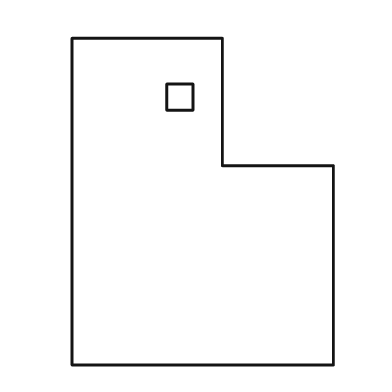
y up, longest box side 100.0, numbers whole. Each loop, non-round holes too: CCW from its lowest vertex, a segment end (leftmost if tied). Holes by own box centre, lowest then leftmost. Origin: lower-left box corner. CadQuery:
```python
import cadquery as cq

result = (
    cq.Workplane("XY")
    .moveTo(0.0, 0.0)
    .lineTo(80.0, 0.0)
    .lineTo(80.0, 61.0)
    .lineTo(46.0, 61.0)
    .lineTo(46.0, 100.0)
    .lineTo(0.0, 100.0)
    .close()
    .moveTo(29.0, 78.0)
    .lineTo(37.0, 78.0)
    .lineTo(37.0, 86.0)
    .lineTo(29.0, 86.0)
    .close()
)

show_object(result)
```